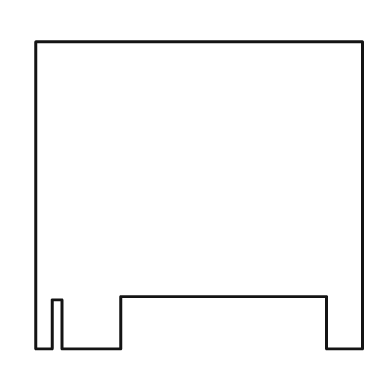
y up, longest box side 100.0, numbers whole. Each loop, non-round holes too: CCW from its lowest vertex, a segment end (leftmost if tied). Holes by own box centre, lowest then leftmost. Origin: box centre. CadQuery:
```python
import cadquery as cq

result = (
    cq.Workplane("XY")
    .moveTo(-50.0, -47.0)
    .lineTo(-45.0, -47.0)
    .lineTo(-45.0, -32.0)
    .lineTo(-42.0, -32.0)
    .lineTo(-42.0, -47.0)
    .lineTo(-24.0, -47.0)
    .lineTo(-24.0, -31.0)
    .lineTo(39.0, -31.0)
    .lineTo(39.0, -47.0)
    .lineTo(50.0, -47.0)
    .lineTo(50.0, 47.0)
    .lineTo(-50.0, 47.0)
    .close()
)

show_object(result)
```